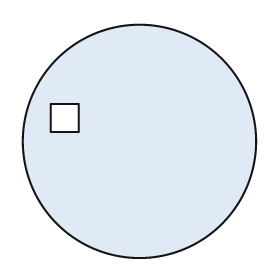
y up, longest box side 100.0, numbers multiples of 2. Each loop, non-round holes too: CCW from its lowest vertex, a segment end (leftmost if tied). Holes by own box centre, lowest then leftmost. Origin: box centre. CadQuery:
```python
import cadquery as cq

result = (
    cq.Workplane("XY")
    .moveTo(0.0, 0.0)
    .circle(50.0)
    .moveTo(-38.0, 4.0)
    .lineTo(-26.0, 4.0)
    .lineTo(-26.0, 16.0)
    .lineTo(-38.0, 16.0)
    .close()
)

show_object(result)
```